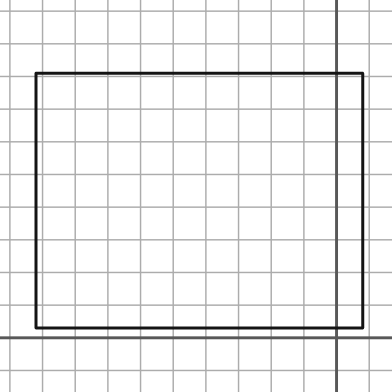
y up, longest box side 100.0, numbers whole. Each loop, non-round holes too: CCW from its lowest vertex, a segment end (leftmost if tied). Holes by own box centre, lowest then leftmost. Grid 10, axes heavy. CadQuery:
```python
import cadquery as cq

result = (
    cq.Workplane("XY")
    .moveTo(-92.0, 3.0)
    .lineTo(8.0, 3.0)
    .lineTo(8.0, 81.0)
    .lineTo(-92.0, 81.0)
    .close()
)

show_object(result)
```